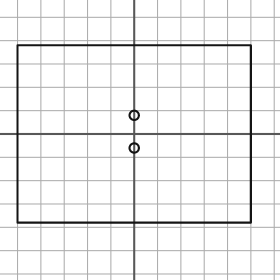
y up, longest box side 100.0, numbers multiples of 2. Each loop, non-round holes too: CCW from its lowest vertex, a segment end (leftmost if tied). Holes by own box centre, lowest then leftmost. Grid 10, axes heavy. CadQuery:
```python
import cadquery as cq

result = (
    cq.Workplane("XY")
    .moveTo(-50.0, -38.0)
    .lineTo(50.0, -38.0)
    .lineTo(50.0, 38.0)
    .lineTo(-50.0, 38.0)
    .close()
    .moveTo(0.0, -6.0)
    .circle(2.0)
    .moveTo(0.0, 8.0)
    .circle(2.0)
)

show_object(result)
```